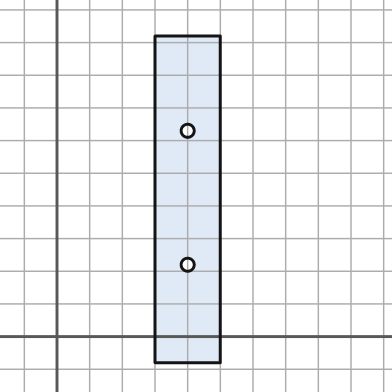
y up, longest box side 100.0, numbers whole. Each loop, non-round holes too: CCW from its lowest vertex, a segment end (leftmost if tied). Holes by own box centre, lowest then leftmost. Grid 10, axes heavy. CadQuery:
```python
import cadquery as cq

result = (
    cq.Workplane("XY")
    .moveTo(30.0, -8.0)
    .lineTo(50.0, -8.0)
    .lineTo(50.0, 92.0)
    .lineTo(30.0, 92.0)
    .close()
    .moveTo(40.0, 22.0)
    .circle(2.0)
    .moveTo(40.0, 63.0)
    .circle(2.0)
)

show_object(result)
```